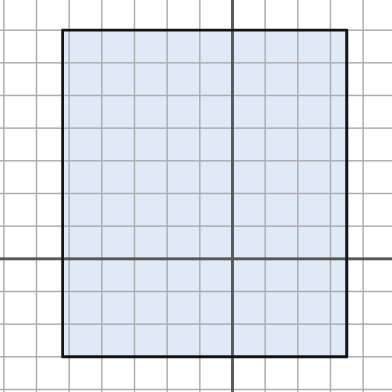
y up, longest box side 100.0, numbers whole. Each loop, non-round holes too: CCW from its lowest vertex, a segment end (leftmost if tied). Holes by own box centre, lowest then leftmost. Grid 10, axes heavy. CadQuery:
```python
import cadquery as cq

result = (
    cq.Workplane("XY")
    .moveTo(-52.0, -30.0)
    .lineTo(35.0, -30.0)
    .lineTo(35.0, 70.0)
    .lineTo(-52.0, 70.0)
    .close()
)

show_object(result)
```